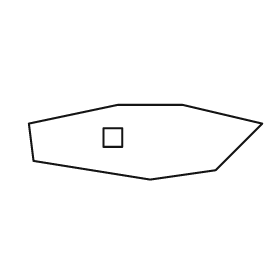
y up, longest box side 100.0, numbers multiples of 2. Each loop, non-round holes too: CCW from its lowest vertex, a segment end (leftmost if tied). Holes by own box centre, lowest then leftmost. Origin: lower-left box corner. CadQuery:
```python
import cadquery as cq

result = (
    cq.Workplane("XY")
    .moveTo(52.0, 0.0)
    .lineTo(80.0, 4.0)
    .lineTo(100.0, 24.0)
    .lineTo(66.0, 32.0)
    .lineTo(38.0, 32.0)
    .lineTo(0.0, 24.0)
    .lineTo(2.0, 8.0)
    .close()
    .moveTo(32.0, 14.0)
    .lineTo(40.0, 14.0)
    .lineTo(40.0, 22.0)
    .lineTo(32.0, 22.0)
    .close()
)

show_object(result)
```